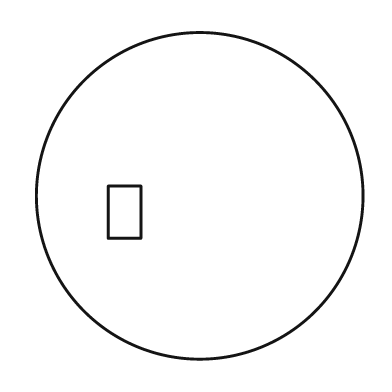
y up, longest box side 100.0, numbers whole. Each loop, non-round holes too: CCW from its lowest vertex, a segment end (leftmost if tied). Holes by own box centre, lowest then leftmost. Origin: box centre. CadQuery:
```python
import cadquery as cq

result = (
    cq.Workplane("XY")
    .moveTo(0.0, 0.0)
    .circle(50.0)
    .moveTo(-28.0, -13.0)
    .lineTo(-18.0, -13.0)
    .lineTo(-18.0, 3.0)
    .lineTo(-28.0, 3.0)
    .close()
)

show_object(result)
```